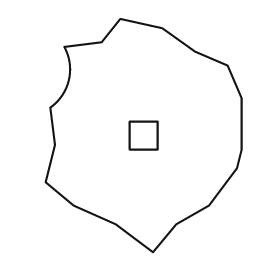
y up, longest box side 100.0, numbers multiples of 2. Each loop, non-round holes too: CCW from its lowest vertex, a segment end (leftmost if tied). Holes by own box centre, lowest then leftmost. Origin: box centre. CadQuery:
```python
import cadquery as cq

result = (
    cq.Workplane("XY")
    .moveTo(4.0, -50.0)
    .lineTo(14.0, -38.0)
    .lineTo(28.0, -30.0)
    .lineTo(40.0, -14.0)
    .lineTo(42.0, -6.0)
    .lineTo(42.0, 16.0)
    .lineTo(36.0, 30.0)
    .lineTo(22.0, 36.0)
    .lineTo(8.0, 46.0)
    .lineTo(-10.0, 50.0)
    .lineTo(-18.0, 40.0)
    .lineTo(-34.0, 38.0)
    .threePointArc((-32.0, 24.0), (-40.0, 12.0))
    .lineTo(-38.0, -4.0)
    .lineTo(-42.0, -20.0)
    .lineTo(-30.0, -30.0)
    .lineTo(-12.0, -38.0)
    .close()
    .moveTo(-6.0, -6.0)
    .lineTo(6.0, -6.0)
    .lineTo(6.0, 6.0)
    .lineTo(-6.0, 6.0)
    .close()
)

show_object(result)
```